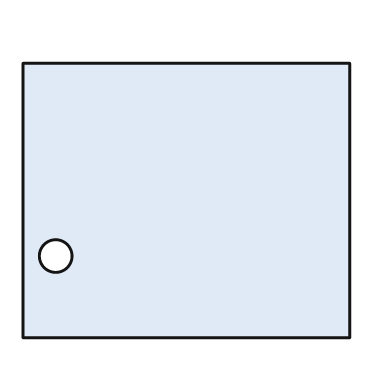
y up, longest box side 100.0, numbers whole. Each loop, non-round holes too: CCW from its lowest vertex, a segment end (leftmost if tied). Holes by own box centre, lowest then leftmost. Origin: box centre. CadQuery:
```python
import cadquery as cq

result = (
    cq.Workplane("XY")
    .moveTo(-50.0, -42.0)
    .lineTo(50.0, -42.0)
    .lineTo(50.0, 42.0)
    .lineTo(-50.0, 42.0)
    .close()
    .moveTo(-40.0, -17.0)
    .circle(5.0)
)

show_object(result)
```